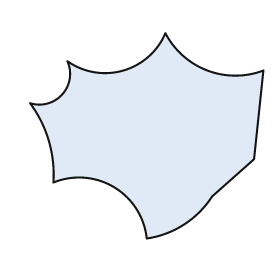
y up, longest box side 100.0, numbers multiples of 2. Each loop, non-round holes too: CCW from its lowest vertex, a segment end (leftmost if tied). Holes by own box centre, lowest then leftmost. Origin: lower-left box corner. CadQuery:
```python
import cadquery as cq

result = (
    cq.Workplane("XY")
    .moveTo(50.0, 0.0)
    .threePointArc((66.0, 6.0), (78.0, 18.0))
    .lineTo(96.0, 34.0)
    .lineTo(100.0, 72.0)
    .threePointArc((76.0, 72.0), (58.0, 88.0))
    .threePointArc((40.0, 72.0), (16.0, 76.0))
    .threePointArc((14.0, 62.0), (0.0, 58.0))
    .threePointArc((8.0, 42.0), (10.0, 24.0))
    .threePointArc((36.0, 22.0), (50.0, 0.0))
    .close()
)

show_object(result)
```